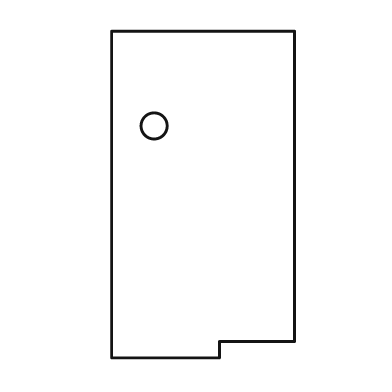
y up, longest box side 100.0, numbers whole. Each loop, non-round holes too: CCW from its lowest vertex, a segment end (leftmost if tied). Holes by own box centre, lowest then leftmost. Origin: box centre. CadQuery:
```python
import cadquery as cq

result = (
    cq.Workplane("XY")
    .moveTo(-28.0, -50.0)
    .lineTo(5.0, -50.0)
    .lineTo(5.0, -45.0)
    .lineTo(28.0, -45.0)
    .lineTo(28.0, 50.0)
    .lineTo(-28.0, 50.0)
    .close()
    .moveTo(-15.0, 21.0)
    .circle(4.0)
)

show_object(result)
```